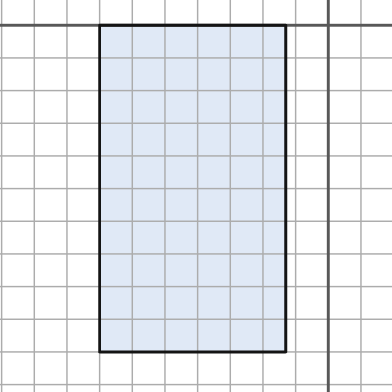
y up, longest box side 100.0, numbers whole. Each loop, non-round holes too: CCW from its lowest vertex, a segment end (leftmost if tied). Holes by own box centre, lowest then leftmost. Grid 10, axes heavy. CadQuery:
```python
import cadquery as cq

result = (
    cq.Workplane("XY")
    .moveTo(-70.0, -100.0)
    .lineTo(-13.0, -100.0)
    .lineTo(-13.0, 0.0)
    .lineTo(-70.0, 0.0)
    .close()
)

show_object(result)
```